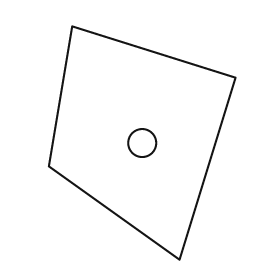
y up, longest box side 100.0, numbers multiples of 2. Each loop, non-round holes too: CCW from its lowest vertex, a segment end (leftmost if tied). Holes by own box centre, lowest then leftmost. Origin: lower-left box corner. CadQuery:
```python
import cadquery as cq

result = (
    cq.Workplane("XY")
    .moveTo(56.0, 0.0)
    .lineTo(80.0, 78.0)
    .lineTo(10.0, 100.0)
    .lineTo(0.0, 40.0)
    .close()
    .moveTo(40.0, 50.0)
    .circle(6.0)
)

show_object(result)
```